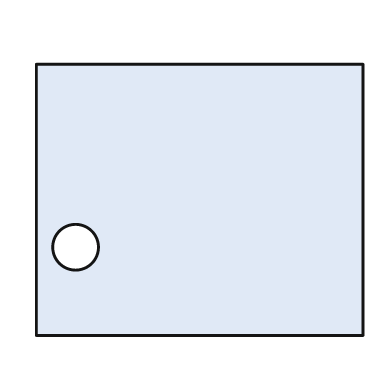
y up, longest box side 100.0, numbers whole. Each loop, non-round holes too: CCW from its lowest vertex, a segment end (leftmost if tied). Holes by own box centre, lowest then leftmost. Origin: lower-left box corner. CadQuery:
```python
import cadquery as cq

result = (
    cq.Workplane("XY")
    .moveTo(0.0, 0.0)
    .lineTo(100.0, 0.0)
    .lineTo(100.0, 83.0)
    .lineTo(0.0, 83.0)
    .close()
    .moveTo(12.0, 27.0)
    .circle(7.0)
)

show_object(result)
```